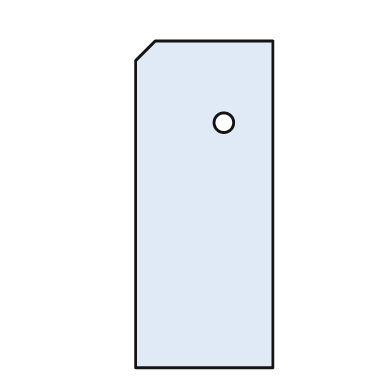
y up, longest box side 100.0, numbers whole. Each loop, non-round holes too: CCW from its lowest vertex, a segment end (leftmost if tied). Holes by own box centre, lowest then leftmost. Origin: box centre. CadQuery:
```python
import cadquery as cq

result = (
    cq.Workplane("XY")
    .moveTo(-21.0, -50.0)
    .lineTo(21.0, -50.0)
    .lineTo(21.0, 50.0)
    .lineTo(-15.0, 50.0)
    .lineTo(-21.0, 44.0)
    .close()
    .moveTo(6.0, 25.0)
    .circle(3.0)
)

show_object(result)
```